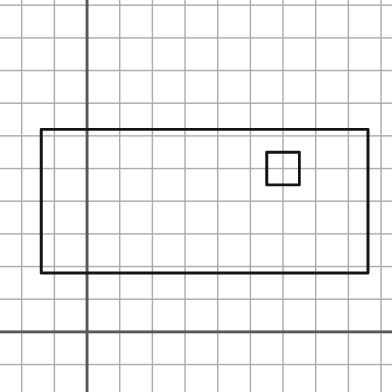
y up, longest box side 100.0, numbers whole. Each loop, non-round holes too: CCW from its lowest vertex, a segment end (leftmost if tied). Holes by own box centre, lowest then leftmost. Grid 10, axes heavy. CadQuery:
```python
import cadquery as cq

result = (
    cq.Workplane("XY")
    .moveTo(-14.0, 18.0)
    .lineTo(86.0, 18.0)
    .lineTo(86.0, 62.0)
    .lineTo(-14.0, 62.0)
    .close()
    .moveTo(55.0, 45.0)
    .lineTo(65.0, 45.0)
    .lineTo(65.0, 55.0)
    .lineTo(55.0, 55.0)
    .close()
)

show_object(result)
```